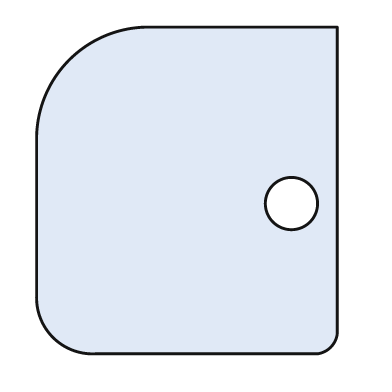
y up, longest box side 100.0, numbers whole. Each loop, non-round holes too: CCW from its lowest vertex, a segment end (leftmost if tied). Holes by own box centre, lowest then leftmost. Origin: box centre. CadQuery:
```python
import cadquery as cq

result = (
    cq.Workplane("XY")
    .moveTo(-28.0, -50.0)
    .lineTo(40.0, -50.0)
    .threePointArc((44.0, -48.0), (46.0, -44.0))
    .lineTo(46.0, 50.0)
    .lineTo(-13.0, 50.0)
    .threePointArc((-36.0, 40.0), (-46.0, 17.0))
    .lineTo(-46.0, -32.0)
    .threePointArc((-41.0, -45.0), (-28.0, -50.0))
    .close()
    .moveTo(32.0, -4.0)
    .circle(8.0)
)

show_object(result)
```